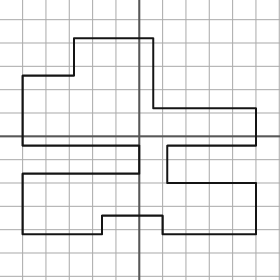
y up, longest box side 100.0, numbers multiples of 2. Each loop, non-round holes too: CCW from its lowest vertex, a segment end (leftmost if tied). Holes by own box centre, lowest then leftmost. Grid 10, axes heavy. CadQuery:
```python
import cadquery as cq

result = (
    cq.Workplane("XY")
    .moveTo(-50.0, -42.0)
    .lineTo(-16.0, -42.0)
    .lineTo(-16.0, -34.0)
    .lineTo(10.0, -34.0)
    .lineTo(10.0, -42.0)
    .lineTo(50.0, -42.0)
    .lineTo(50.0, -20.0)
    .lineTo(12.0, -20.0)
    .lineTo(12.0, -4.0)
    .lineTo(50.0, -4.0)
    .lineTo(50.0, 12.0)
    .lineTo(6.0, 12.0)
    .lineTo(6.0, 42.0)
    .lineTo(-28.0, 42.0)
    .lineTo(-28.0, 26.0)
    .lineTo(-50.0, 26.0)
    .lineTo(-50.0, -4.0)
    .lineTo(0.0, -4.0)
    .lineTo(0.0, -16.0)
    .lineTo(-50.0, -16.0)
    .close()
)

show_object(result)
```